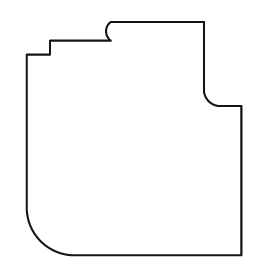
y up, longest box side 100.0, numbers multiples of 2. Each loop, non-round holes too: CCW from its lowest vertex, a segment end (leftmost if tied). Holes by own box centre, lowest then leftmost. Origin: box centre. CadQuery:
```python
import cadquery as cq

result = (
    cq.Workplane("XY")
    .moveTo(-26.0, -50.0)
    .lineTo(46.0, -50.0)
    .lineTo(46.0, 14.0)
    .lineTo(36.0, 14.0)
    .threePointArc((32.0, 16.0), (30.0, 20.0))
    .lineTo(30.0, 50.0)
    .lineTo(-10.0, 50.0)
    .threePointArc((-12.0, 46.0), (-10.0, 42.0))
    .lineTo(-36.0, 42.0)
    .lineTo(-36.0, 36.0)
    .lineTo(-46.0, 36.0)
    .lineTo(-46.0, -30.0)
    .threePointArc((-40.0, -44.0), (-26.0, -50.0))
    .close()
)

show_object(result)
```